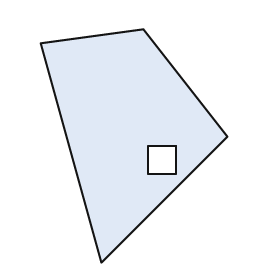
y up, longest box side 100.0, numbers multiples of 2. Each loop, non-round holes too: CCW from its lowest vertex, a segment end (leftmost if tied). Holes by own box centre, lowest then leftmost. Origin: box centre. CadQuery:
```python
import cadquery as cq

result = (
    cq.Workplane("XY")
    .moveTo(-14.0, -50.0)
    .lineTo(40.0, 4.0)
    .lineTo(4.0, 50.0)
    .lineTo(-40.0, 44.0)
    .close()
    .moveTo(6.0, -12.0)
    .lineTo(18.0, -12.0)
    .lineTo(18.0, 0.0)
    .lineTo(6.0, 0.0)
    .close()
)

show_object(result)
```